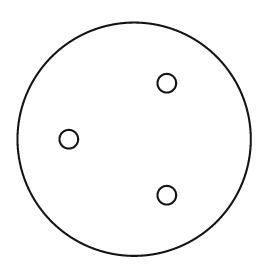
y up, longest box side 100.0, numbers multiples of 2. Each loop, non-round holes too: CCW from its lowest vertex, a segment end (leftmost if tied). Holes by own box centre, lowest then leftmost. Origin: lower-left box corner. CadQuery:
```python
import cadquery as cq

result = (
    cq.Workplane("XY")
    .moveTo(50.0, 50.0)
    .circle(50.0)
    .moveTo(64.0, 26.0)
    .circle(4.0)
    .moveTo(22.0, 50.0)
    .circle(4.0)
    .moveTo(64.0, 74.0)
    .circle(4.0)
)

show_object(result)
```